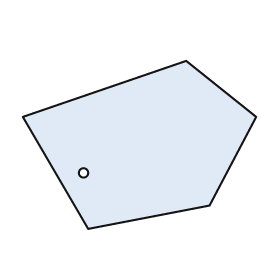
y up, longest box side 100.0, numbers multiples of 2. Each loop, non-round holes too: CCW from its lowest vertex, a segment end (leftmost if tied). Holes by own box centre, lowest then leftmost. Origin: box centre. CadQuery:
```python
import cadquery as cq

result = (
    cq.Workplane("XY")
    .moveTo(-22.0, -36.0)
    .lineTo(30.0, -26.0)
    .lineTo(50.0, 12.0)
    .lineTo(20.0, 36.0)
    .lineTo(-50.0, 12.0)
    .close()
    .moveTo(-24.0, -12.0)
    .circle(2.0)
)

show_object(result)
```